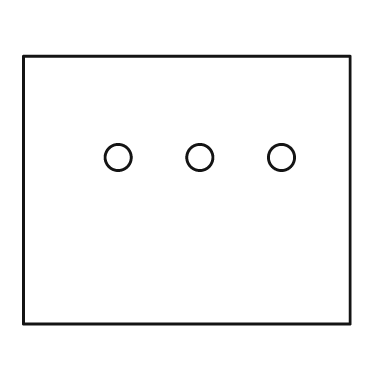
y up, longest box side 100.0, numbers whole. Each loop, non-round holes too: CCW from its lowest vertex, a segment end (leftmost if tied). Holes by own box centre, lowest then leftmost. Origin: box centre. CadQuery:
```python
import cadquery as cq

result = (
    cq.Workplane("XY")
    .moveTo(-50.0, -41.0)
    .lineTo(50.0, -41.0)
    .lineTo(50.0, 41.0)
    .lineTo(-50.0, 41.0)
    .close()
    .moveTo(-21.0, 10.0)
    .circle(4.0)
    .moveTo(4.0, 10.0)
    .circle(4.0)
    .moveTo(29.0, 10.0)
    .circle(4.0)
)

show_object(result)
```